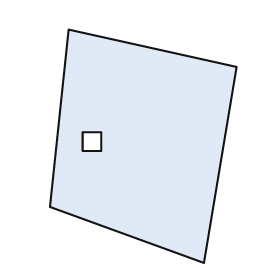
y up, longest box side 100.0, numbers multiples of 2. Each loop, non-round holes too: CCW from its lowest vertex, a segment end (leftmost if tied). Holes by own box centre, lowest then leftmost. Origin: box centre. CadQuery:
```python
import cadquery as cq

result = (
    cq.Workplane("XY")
    .moveTo(26.0, -50.0)
    .lineTo(40.0, 34.0)
    .lineTo(-32.0, 50.0)
    .lineTo(-40.0, -26.0)
    .close()
    .moveTo(-26.0, -2.0)
    .lineTo(-18.0, -2.0)
    .lineTo(-18.0, 6.0)
    .lineTo(-26.0, 6.0)
    .close()
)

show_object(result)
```